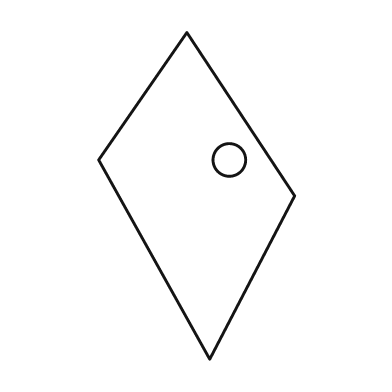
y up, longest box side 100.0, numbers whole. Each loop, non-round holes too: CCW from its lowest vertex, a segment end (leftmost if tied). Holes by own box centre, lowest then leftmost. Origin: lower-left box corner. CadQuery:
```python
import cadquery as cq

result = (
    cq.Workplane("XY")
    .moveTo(34.0, 0.0)
    .lineTo(60.0, 50.0)
    .lineTo(27.0, 100.0)
    .lineTo(0.0, 61.0)
    .close()
    .moveTo(40.0, 61.0)
    .circle(5.0)
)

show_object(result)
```